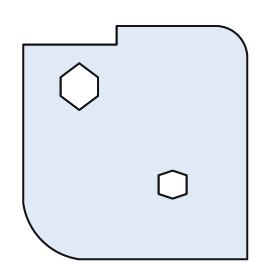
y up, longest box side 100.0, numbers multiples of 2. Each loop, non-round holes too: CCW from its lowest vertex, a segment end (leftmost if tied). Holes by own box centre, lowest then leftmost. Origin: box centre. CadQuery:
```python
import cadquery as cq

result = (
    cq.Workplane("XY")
    .moveTo(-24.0, -50.0)
    .lineTo(48.0, -50.0)
    .lineTo(48.0, 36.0)
    .threePointArc((44.0, 46.0), (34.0, 50.0))
    .lineTo(-8.0, 50.0)
    .lineTo(-8.0, 42.0)
    .lineTo(-48.0, 42.0)
    .lineTo(-48.0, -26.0)
    .threePointArc((-40.0, -42.0), (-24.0, -50.0))
    .close()
    .moveTo(16.0, -24.0)
    .lineTo(22.0, -22.0)
    .lineTo(22.0, -14.0)
    .lineTo(16.0, -12.0)
    .lineTo(10.0, -14.0)
    .lineTo(10.0, -22.0)
    .close()
    .moveTo(-24.0, 14.0)
    .lineTo(-16.0, 20.0)
    .lineTo(-16.0, 28.0)
    .lineTo(-24.0, 34.0)
    .lineTo(-32.0, 28.0)
    .lineTo(-32.0, 20.0)
    .close()
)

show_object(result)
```